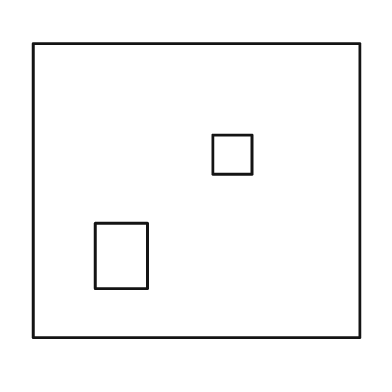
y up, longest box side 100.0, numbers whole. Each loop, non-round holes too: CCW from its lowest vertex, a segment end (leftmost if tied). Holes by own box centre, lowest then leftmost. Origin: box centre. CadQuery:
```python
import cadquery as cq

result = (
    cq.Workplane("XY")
    .moveTo(-50.0, -45.0)
    .lineTo(50.0, -45.0)
    .lineTo(50.0, 45.0)
    .lineTo(-50.0, 45.0)
    .close()
    .moveTo(-31.0, -30.0)
    .lineTo(-15.0, -30.0)
    .lineTo(-15.0, -10.0)
    .lineTo(-31.0, -10.0)
    .close()
    .moveTo(5.0, 5.0)
    .lineTo(17.0, 5.0)
    .lineTo(17.0, 17.0)
    .lineTo(5.0, 17.0)
    .close()
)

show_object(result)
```